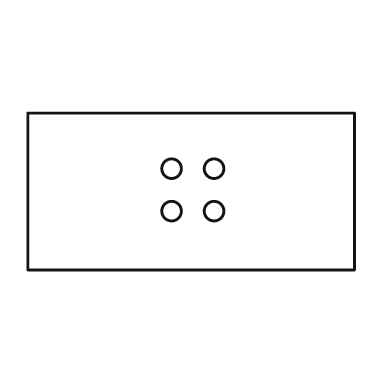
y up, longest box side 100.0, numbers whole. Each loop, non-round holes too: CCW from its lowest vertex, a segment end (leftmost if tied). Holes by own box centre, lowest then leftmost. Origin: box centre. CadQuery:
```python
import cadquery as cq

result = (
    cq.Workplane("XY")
    .moveTo(-50.0, -24.0)
    .lineTo(50.0, -24.0)
    .lineTo(50.0, 24.0)
    .lineTo(-50.0, 24.0)
    .close()
    .moveTo(-6.0, -6.0)
    .circle(3.0)
    .moveTo(7.0, -6.0)
    .circle(3.0)
    .moveTo(-6.0, 7.0)
    .circle(3.0)
    .moveTo(7.0, 7.0)
    .circle(3.0)
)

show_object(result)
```